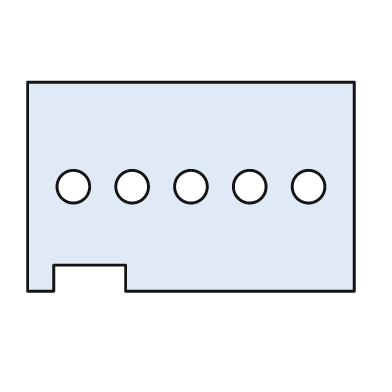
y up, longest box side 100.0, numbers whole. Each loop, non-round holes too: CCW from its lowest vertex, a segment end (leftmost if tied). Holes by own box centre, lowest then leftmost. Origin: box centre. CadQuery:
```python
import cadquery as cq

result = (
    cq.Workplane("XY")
    .moveTo(-50.0, -32.0)
    .lineTo(-42.0, -32.0)
    .lineTo(-42.0, -24.0)
    .lineTo(-20.0, -24.0)
    .lineTo(-20.0, -32.0)
    .lineTo(50.0, -32.0)
    .lineTo(50.0, 32.0)
    .lineTo(-50.0, 32.0)
    .close()
    .moveTo(-36.0, 0.0)
    .circle(5.0)
    .moveTo(-18.0, 0.0)
    .circle(5.0)
    .moveTo(0.0, 0.0)
    .circle(5.0)
    .moveTo(18.0, 0.0)
    .circle(5.0)
    .moveTo(36.0, 0.0)
    .circle(5.0)
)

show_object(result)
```